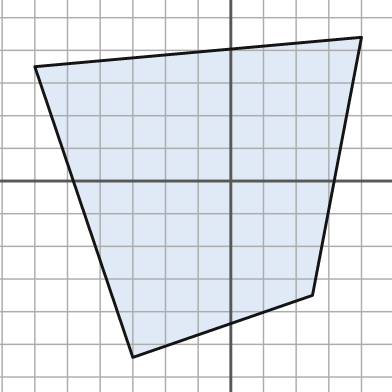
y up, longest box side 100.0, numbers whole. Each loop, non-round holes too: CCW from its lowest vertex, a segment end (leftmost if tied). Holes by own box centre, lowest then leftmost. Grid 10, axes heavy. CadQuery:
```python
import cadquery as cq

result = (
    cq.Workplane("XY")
    .moveTo(-30.0, -54.0)
    .lineTo(25.0, -35.0)
    .lineTo(40.0, 44.0)
    .lineTo(-60.0, 35.0)
    .close()
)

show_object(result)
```